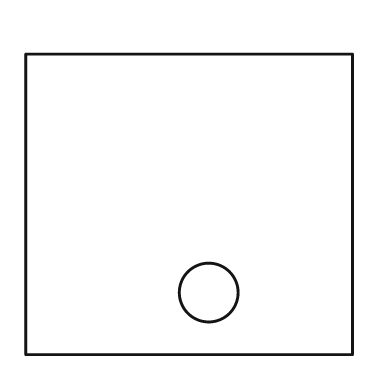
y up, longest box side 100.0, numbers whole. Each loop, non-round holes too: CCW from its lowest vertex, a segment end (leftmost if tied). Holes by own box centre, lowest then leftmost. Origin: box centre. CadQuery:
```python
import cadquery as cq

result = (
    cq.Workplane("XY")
    .moveTo(-50.0, -46.0)
    .lineTo(50.0, -46.0)
    .lineTo(50.0, 46.0)
    .lineTo(-50.0, 46.0)
    .close()
    .moveTo(6.0, -27.0)
    .circle(9.0)
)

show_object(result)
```